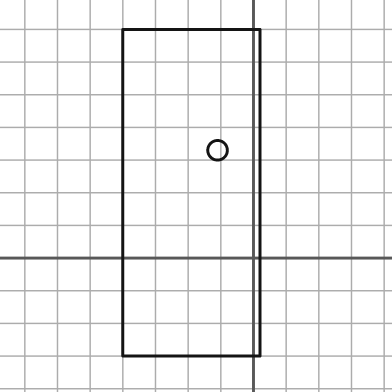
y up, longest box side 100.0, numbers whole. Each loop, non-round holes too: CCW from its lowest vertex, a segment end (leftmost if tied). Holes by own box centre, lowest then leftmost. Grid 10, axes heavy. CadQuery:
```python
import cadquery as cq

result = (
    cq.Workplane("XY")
    .moveTo(-40.0, -30.0)
    .lineTo(2.0, -30.0)
    .lineTo(2.0, 70.0)
    .lineTo(-40.0, 70.0)
    .close()
    .moveTo(-11.0, 33.0)
    .circle(3.0)
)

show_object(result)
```